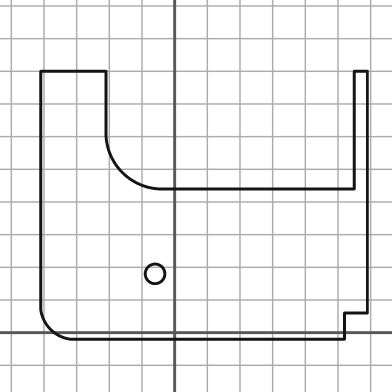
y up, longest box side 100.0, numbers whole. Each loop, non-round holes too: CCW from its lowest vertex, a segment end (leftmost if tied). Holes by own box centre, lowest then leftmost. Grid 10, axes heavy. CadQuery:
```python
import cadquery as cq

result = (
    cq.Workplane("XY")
    .moveTo(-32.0, -2.0)
    .lineTo(52.0, -2.0)
    .lineTo(52.0, 6.0)
    .lineTo(59.0, 6.0)
    .lineTo(59.0, 80.0)
    .lineTo(55.0, 80.0)
    .lineTo(55.0, 44.0)
    .lineTo(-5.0, 44.0)
    .threePointArc((-16.0, 49.0), (-21.0, 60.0))
    .lineTo(-21.0, 80.0)
    .lineTo(-41.0, 80.0)
    .lineTo(-41.0, 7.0)
    .threePointArc((-38.0, 1.0), (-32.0, -2.0))
    .close()
    .moveTo(-6.0, 18.0)
    .circle(3.0)
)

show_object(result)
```